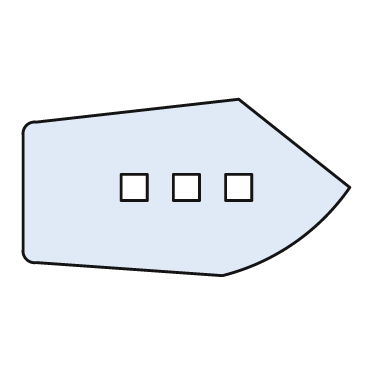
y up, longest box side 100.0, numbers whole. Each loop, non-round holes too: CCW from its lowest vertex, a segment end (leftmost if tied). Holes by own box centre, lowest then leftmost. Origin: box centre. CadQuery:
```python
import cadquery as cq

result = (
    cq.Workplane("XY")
    .moveTo(11.0, -27.0)
    .threePointArc((33.0, -17.0), (50.0, 0.0))
    .lineTo(16.0, 27.0)
    .lineTo(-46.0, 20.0)
    .threePointArc((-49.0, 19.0), (-50.0, 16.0))
    .lineTo(-50.0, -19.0)
    .threePointArc((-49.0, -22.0), (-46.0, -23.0))
    .close()
    .moveTo(-20.0, -4.0)
    .lineTo(-12.0, -4.0)
    .lineTo(-12.0, 4.0)
    .lineTo(-20.0, 4.0)
    .close()
    .moveTo(-4.0, -4.0)
    .lineTo(4.0, -4.0)
    .lineTo(4.0, 4.0)
    .lineTo(-4.0, 4.0)
    .close()
    .moveTo(12.0, -4.0)
    .lineTo(20.0, -4.0)
    .lineTo(20.0, 4.0)
    .lineTo(12.0, 4.0)
    .close()
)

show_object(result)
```